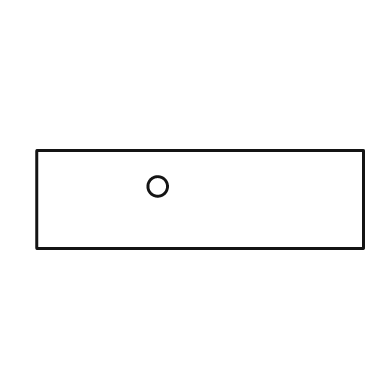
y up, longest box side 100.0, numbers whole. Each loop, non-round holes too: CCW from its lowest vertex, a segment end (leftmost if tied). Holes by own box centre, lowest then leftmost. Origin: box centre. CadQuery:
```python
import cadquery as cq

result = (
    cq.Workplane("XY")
    .moveTo(-50.0, -15.0)
    .lineTo(50.0, -15.0)
    .lineTo(50.0, 15.0)
    .lineTo(-50.0, 15.0)
    .close()
    .moveTo(-13.0, 4.0)
    .circle(3.0)
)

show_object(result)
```